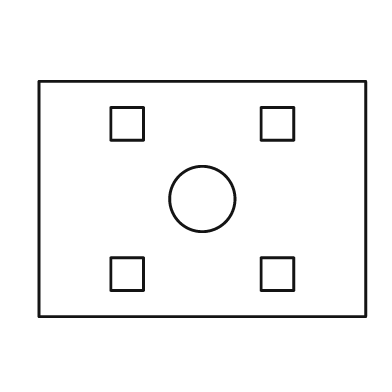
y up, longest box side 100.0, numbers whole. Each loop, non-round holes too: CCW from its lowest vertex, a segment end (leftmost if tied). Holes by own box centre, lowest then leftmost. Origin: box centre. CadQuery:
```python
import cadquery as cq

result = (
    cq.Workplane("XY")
    .moveTo(-50.0, -36.0)
    .lineTo(50.0, -36.0)
    .lineTo(50.0, 36.0)
    .lineTo(-50.0, 36.0)
    .close()
    .moveTo(-28.0, -28.0)
    .lineTo(-18.0, -28.0)
    .lineTo(-18.0, -18.0)
    .lineTo(-28.0, -18.0)
    .close()
    .moveTo(18.0, -28.0)
    .lineTo(28.0, -28.0)
    .lineTo(28.0, -18.0)
    .lineTo(18.0, -18.0)
    .close()
    .moveTo(0.0, 0.0)
    .circle(10.0)
    .moveTo(-28.0, 18.0)
    .lineTo(-18.0, 18.0)
    .lineTo(-18.0, 28.0)
    .lineTo(-28.0, 28.0)
    .close()
    .moveTo(18.0, 18.0)
    .lineTo(28.0, 18.0)
    .lineTo(28.0, 28.0)
    .lineTo(18.0, 28.0)
    .close()
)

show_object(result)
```